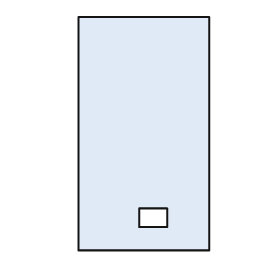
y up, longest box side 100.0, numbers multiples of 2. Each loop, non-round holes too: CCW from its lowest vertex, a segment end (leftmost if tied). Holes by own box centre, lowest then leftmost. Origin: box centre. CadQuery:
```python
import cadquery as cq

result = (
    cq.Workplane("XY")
    .moveTo(-28.0, -50.0)
    .lineTo(28.0, -50.0)
    .lineTo(28.0, 50.0)
    .lineTo(-28.0, 50.0)
    .close()
    .moveTo(-2.0, -40.0)
    .lineTo(10.0, -40.0)
    .lineTo(10.0, -32.0)
    .lineTo(-2.0, -32.0)
    .close()
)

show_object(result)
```